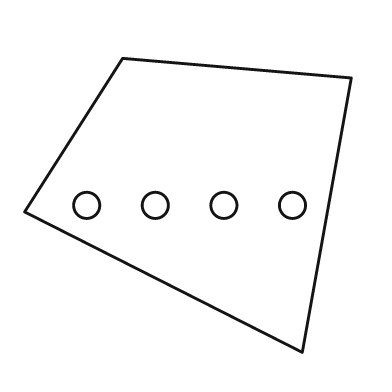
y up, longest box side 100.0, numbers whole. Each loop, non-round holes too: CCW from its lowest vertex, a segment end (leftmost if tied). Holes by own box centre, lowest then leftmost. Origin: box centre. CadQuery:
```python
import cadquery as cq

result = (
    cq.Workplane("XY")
    .moveTo(35.0, -45.0)
    .lineTo(50.0, 39.0)
    .lineTo(-20.0, 45.0)
    .lineTo(-50.0, -2.0)
    .close()
    .moveTo(-31.0, 0.0)
    .circle(4.0)
    .moveTo(-10.0, 0.0)
    .circle(4.0)
    .moveTo(11.0, 0.0)
    .circle(4.0)
    .moveTo(32.0, 0.0)
    .circle(4.0)
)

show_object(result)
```